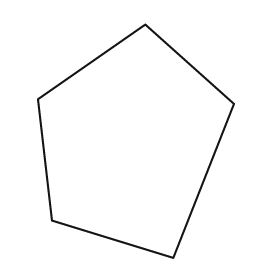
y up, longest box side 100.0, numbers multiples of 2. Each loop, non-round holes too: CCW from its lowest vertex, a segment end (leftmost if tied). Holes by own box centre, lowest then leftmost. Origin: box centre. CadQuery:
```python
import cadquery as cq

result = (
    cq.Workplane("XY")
    .moveTo(16.0, -50.0)
    .lineTo(42.0, 16.0)
    .lineTo(4.0, 50.0)
    .lineTo(-42.0, 18.0)
    .lineTo(-36.0, -34.0)
    .close()
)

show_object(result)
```